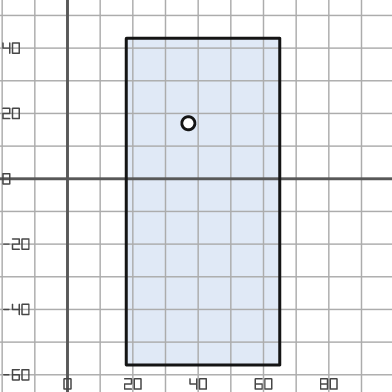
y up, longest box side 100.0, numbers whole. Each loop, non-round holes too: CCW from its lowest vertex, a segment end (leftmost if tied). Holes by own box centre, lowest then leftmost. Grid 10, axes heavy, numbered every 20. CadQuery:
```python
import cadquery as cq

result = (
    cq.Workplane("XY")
    .moveTo(18.0, -57.0)
    .lineTo(65.0, -57.0)
    .lineTo(65.0, 43.0)
    .lineTo(18.0, 43.0)
    .close()
    .moveTo(37.0, 17.0)
    .circle(2.0)
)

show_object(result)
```